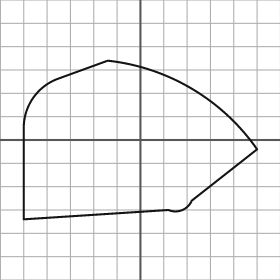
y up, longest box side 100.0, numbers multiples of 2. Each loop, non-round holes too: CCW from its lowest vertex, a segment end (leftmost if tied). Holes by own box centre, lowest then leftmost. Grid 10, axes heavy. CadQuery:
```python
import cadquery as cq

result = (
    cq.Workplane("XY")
    .moveTo(-50.0, -34.0)
    .lineTo(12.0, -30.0)
    .threePointArc((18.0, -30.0), (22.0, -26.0))
    .lineTo(50.0, -4.0)
    .threePointArc((22.0, 22.0), (-14.0, 34.0))
    .lineTo(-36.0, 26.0)
    .threePointArc((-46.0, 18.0), (-50.0, 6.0))
    .close()
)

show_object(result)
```